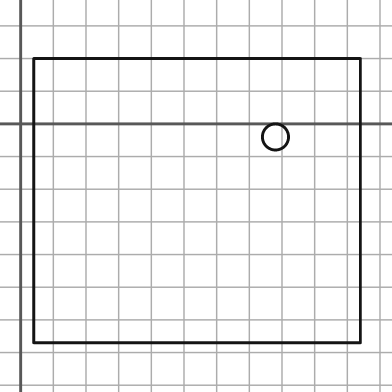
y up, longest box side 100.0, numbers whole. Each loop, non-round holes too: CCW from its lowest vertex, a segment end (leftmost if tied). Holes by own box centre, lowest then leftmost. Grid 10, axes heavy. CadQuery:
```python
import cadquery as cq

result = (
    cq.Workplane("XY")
    .moveTo(4.0, -67.0)
    .lineTo(104.0, -67.0)
    .lineTo(104.0, 20.0)
    .lineTo(4.0, 20.0)
    .close()
    .moveTo(78.0, -4.0)
    .circle(4.0)
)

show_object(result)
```